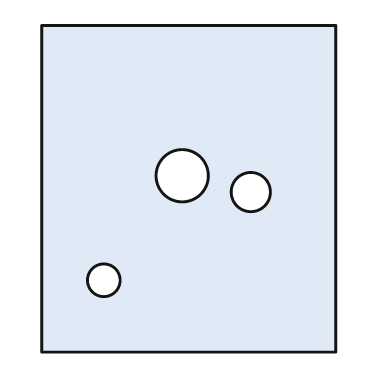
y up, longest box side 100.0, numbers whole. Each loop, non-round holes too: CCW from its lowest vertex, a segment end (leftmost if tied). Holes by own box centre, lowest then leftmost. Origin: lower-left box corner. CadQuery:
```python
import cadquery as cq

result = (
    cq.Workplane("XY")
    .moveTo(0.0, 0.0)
    .lineTo(90.0, 0.0)
    .lineTo(90.0, 100.0)
    .lineTo(0.0, 100.0)
    .close()
    .moveTo(19.0, 22.0)
    .circle(5.0)
    .moveTo(64.0, 49.0)
    .circle(6.0)
    .moveTo(43.0, 54.0)
    .circle(8.0)
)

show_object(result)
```